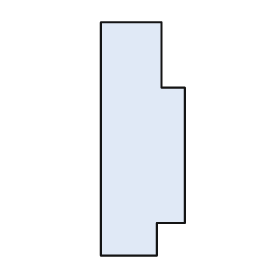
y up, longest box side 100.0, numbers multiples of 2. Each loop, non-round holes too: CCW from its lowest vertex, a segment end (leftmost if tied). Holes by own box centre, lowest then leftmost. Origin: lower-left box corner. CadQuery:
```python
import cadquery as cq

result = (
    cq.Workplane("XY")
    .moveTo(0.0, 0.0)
    .lineTo(24.0, 0.0)
    .lineTo(24.0, 14.0)
    .lineTo(36.0, 14.0)
    .lineTo(36.0, 72.0)
    .lineTo(26.0, 72.0)
    .lineTo(26.0, 100.0)
    .lineTo(0.0, 100.0)
    .close()
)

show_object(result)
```